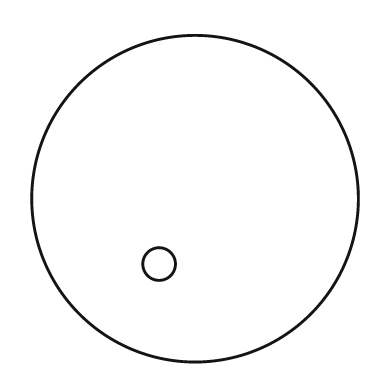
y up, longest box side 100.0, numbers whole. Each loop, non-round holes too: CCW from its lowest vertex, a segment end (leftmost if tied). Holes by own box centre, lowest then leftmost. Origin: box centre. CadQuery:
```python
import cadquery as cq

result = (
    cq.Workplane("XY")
    .moveTo(0.0, 0.0)
    .circle(50.0)
    .moveTo(-11.0, -20.0)
    .circle(5.0)
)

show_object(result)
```